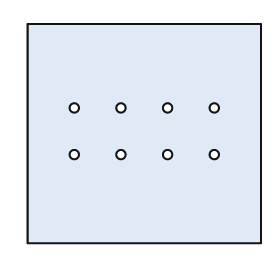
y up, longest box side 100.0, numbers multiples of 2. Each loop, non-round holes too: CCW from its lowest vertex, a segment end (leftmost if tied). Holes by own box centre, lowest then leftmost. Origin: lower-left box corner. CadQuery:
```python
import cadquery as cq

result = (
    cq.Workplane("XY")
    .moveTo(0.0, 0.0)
    .lineTo(100.0, 0.0)
    .lineTo(100.0, 94.0)
    .lineTo(0.0, 94.0)
    .close()
    .moveTo(20.0, 38.0)
    .circle(2.0)
    .moveTo(40.0, 38.0)
    .circle(2.0)
    .moveTo(60.0, 38.0)
    .circle(2.0)
    .moveTo(80.0, 38.0)
    .circle(2.0)
    .moveTo(20.0, 58.0)
    .circle(2.0)
    .moveTo(40.0, 58.0)
    .circle(2.0)
    .moveTo(60.0, 58.0)
    .circle(2.0)
    .moveTo(80.0, 58.0)
    .circle(2.0)
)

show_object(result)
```